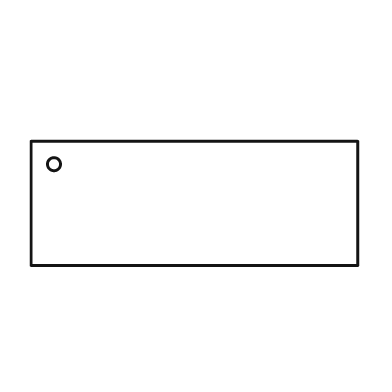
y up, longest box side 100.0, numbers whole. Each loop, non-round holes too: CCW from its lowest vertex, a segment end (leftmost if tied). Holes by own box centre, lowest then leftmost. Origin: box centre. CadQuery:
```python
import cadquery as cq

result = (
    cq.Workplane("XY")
    .moveTo(-50.0, -19.0)
    .lineTo(50.0, -19.0)
    .lineTo(50.0, 19.0)
    .lineTo(-50.0, 19.0)
    .close()
    .moveTo(-43.0, 12.0)
    .circle(2.0)
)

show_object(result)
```